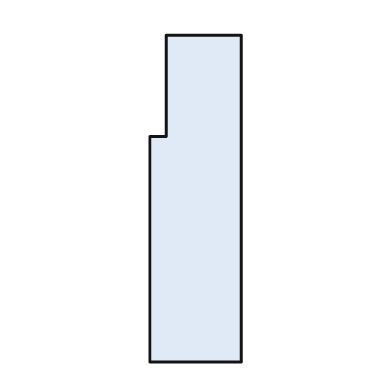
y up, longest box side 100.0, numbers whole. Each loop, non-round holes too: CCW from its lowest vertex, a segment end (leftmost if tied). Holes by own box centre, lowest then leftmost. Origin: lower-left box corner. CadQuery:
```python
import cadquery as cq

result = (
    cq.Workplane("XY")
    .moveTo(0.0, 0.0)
    .lineTo(28.0, 0.0)
    .lineTo(28.0, 100.0)
    .lineTo(5.0, 100.0)
    .lineTo(5.0, 69.0)
    .lineTo(0.0, 69.0)
    .close()
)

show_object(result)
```